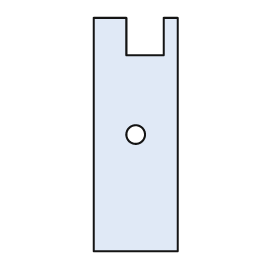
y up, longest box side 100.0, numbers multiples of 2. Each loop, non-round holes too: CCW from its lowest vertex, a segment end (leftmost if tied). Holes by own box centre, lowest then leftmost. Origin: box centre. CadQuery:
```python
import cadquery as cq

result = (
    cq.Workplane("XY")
    .moveTo(-18.0, -50.0)
    .lineTo(18.0, -50.0)
    .lineTo(18.0, 50.0)
    .lineTo(12.0, 50.0)
    .lineTo(12.0, 34.0)
    .lineTo(-4.0, 34.0)
    .lineTo(-4.0, 50.0)
    .lineTo(-18.0, 50.0)
    .close()
    .moveTo(0.0, 0.0)
    .circle(4.0)
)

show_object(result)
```